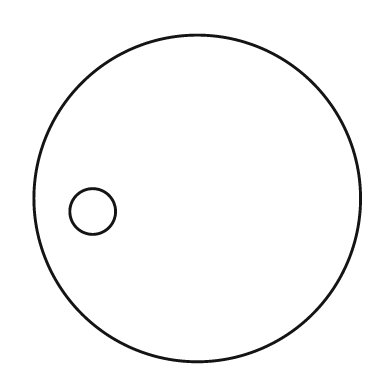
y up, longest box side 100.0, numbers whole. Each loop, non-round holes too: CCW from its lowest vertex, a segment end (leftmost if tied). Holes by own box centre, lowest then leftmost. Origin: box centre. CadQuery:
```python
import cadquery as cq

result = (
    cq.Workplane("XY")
    .moveTo(0.0, 0.0)
    .circle(50.0)
    .moveTo(-32.0, -4.0)
    .circle(7.0)
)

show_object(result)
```